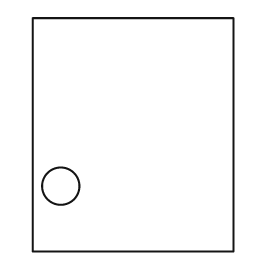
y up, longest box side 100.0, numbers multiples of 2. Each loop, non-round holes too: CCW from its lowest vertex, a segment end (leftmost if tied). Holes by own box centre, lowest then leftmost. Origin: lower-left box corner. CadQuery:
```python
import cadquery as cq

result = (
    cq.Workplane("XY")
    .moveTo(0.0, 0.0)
    .lineTo(86.0, 0.0)
    .lineTo(86.0, 100.0)
    .lineTo(0.0, 100.0)
    .close()
    .moveTo(12.0, 28.0)
    .circle(8.0)
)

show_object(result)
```